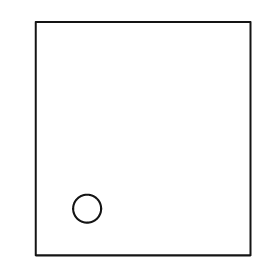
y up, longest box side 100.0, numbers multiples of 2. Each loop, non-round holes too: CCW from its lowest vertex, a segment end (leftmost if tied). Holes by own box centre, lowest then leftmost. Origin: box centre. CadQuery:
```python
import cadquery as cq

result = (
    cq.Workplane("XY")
    .moveTo(-46.0, -50.0)
    .lineTo(46.0, -50.0)
    .lineTo(46.0, 50.0)
    .lineTo(-46.0, 50.0)
    .close()
    .moveTo(-24.0, -30.0)
    .circle(6.0)
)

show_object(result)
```